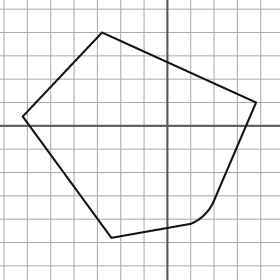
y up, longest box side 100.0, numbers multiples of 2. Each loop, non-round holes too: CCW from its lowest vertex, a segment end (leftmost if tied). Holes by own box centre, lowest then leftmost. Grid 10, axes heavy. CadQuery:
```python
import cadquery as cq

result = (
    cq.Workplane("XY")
    .moveTo(-24.0, -48.0)
    .lineTo(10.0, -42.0)
    .threePointArc((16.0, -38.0), (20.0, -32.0))
    .lineTo(38.0, 10.0)
    .lineTo(-28.0, 40.0)
    .lineTo(-62.0, 4.0)
    .close()
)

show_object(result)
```